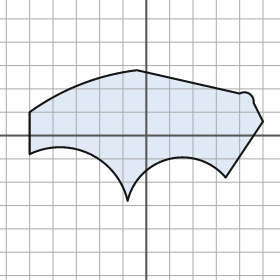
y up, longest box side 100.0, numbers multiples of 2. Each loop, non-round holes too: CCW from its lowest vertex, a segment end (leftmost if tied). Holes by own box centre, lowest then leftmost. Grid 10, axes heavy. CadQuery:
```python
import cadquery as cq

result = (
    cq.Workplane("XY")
    .moveTo(-8.0, -28.0)
    .threePointArc((10.0, -10.0), (34.0, -18.0))
    .lineTo(50.0, 6.0)
    .lineTo(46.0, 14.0)
    .threePointArc((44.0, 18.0), (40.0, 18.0))
    .lineTo(-4.0, 28.0)
    .threePointArc((-28.0, 22.0), (-50.0, 10.0))
    .lineTo(-50.0, -8.0)
    .threePointArc((-24.0, -8.0), (-8.0, -28.0))
    .close()
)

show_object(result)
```